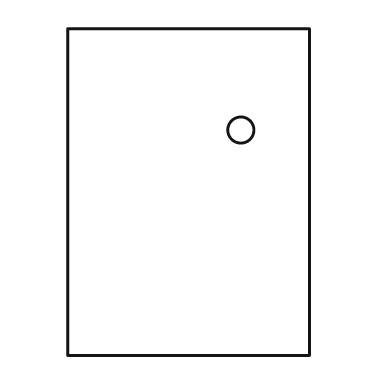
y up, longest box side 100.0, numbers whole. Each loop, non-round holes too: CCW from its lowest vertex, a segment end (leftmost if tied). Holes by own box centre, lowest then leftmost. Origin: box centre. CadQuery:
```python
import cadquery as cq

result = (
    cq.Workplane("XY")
    .moveTo(-37.0, -50.0)
    .lineTo(37.0, -50.0)
    .lineTo(37.0, 50.0)
    .lineTo(-37.0, 50.0)
    .close()
    .moveTo(16.0, 19.0)
    .circle(4.0)
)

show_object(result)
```